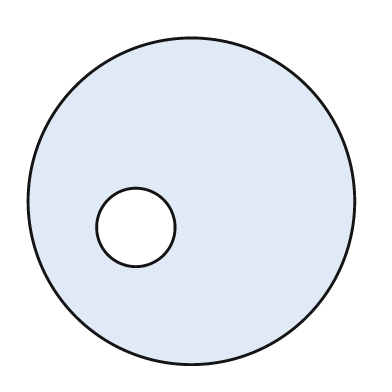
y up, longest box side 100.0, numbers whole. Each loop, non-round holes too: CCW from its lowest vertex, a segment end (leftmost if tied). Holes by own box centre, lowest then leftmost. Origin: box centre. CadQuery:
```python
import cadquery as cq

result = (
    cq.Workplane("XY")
    .moveTo(0.0, 0.0)
    .circle(50.0)
    .moveTo(-17.0, -8.0)
    .circle(12.0)
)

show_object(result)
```